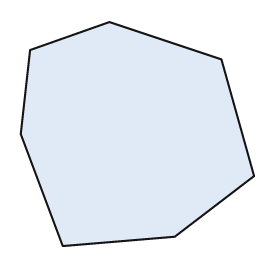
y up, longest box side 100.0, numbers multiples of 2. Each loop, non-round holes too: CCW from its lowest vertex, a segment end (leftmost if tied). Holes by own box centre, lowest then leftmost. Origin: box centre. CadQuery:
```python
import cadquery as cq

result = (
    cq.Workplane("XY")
    .moveTo(-32.0, -48.0)
    .lineTo(16.0, -44.0)
    .lineTo(50.0, -18.0)
    .lineTo(36.0, 32.0)
    .lineTo(-12.0, 48.0)
    .lineTo(-46.0, 36.0)
    .lineTo(-50.0, 0.0)
    .close()
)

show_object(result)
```